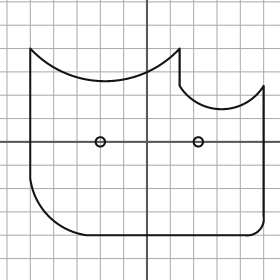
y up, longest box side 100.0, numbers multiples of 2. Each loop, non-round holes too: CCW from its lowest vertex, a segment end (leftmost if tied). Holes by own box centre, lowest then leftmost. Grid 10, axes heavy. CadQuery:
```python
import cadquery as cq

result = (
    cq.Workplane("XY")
    .moveTo(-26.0, -40.0)
    .lineTo(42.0, -40.0)
    .threePointArc((48.0, -38.0), (50.0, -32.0))
    .lineTo(50.0, 24.0)
    .threePointArc((32.0, 14.0), (14.0, 24.0))
    .lineTo(14.0, 40.0)
    .threePointArc((-18.0, 26.0), (-50.0, 40.0))
    .lineTo(-50.0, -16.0)
    .threePointArc((-42.0, -32.0), (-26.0, -40.0))
    .close()
    .moveTo(-20.0, 0.0)
    .circle(2.0)
    .moveTo(22.0, 0.0)
    .circle(2.0)
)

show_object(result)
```